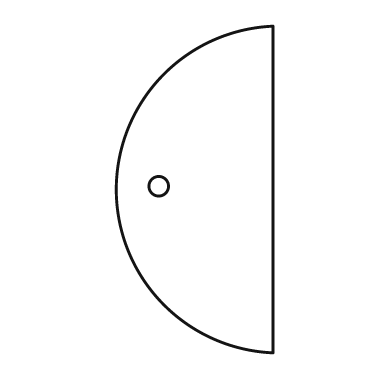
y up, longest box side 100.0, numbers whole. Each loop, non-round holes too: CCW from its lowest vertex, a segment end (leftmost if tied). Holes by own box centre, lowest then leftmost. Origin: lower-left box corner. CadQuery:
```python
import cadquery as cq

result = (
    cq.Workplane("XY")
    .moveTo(48.0, 0.0)
    .lineTo(48.0, 100.0)
    .threePointArc((0.0, 50.0), (48.0, 0.0))
    .close()
    .moveTo(13.0, 51.0)
    .circle(3.0)
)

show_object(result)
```